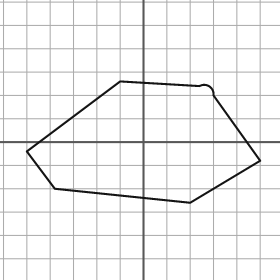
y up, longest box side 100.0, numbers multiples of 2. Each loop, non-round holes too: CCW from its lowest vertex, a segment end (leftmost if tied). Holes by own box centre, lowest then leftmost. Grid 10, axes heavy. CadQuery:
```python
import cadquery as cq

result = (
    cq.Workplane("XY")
    .moveTo(20.0, -26.0)
    .lineTo(50.0, -8.0)
    .lineTo(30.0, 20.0)
    .threePointArc((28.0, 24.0), (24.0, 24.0))
    .lineTo(-10.0, 26.0)
    .lineTo(-50.0, -4.0)
    .lineTo(-38.0, -20.0)
    .close()
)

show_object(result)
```